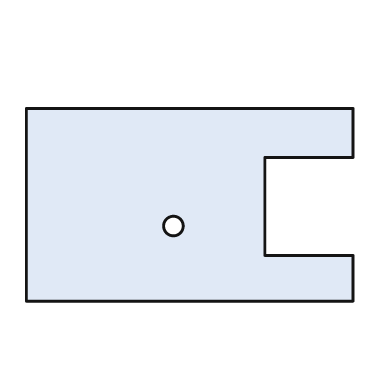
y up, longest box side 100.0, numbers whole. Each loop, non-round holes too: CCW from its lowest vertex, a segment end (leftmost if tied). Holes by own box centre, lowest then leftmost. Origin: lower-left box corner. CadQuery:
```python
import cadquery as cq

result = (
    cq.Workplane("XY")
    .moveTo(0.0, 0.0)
    .lineTo(100.0, 0.0)
    .lineTo(100.0, 14.0)
    .lineTo(73.0, 14.0)
    .lineTo(73.0, 44.0)
    .lineTo(100.0, 44.0)
    .lineTo(100.0, 59.0)
    .lineTo(0.0, 59.0)
    .close()
    .moveTo(45.0, 23.0)
    .circle(3.0)
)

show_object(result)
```